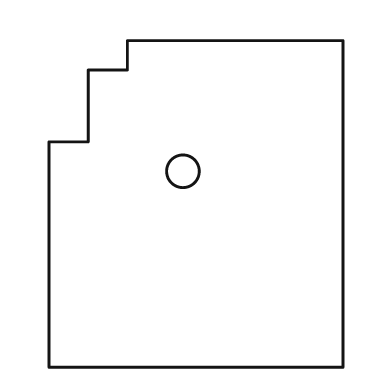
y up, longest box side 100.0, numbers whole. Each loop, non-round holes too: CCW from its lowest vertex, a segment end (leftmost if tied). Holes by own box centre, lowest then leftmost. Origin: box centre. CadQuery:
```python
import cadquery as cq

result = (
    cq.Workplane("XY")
    .moveTo(-45.0, -50.0)
    .lineTo(45.0, -50.0)
    .lineTo(45.0, 50.0)
    .lineTo(-21.0, 50.0)
    .lineTo(-21.0, 41.0)
    .lineTo(-33.0, 41.0)
    .lineTo(-33.0, 19.0)
    .lineTo(-45.0, 19.0)
    .close()
    .moveTo(-4.0, 10.0)
    .circle(5.0)
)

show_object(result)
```